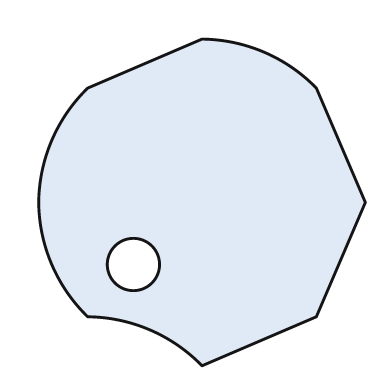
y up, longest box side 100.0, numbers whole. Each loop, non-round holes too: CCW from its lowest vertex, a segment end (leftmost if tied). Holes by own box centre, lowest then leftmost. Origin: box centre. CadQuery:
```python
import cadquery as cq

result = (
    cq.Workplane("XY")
    .moveTo(0.0, -50.0)
    .lineTo(35.0, -35.0)
    .lineTo(50.0, 0.0)
    .lineTo(35.0, 35.0)
    .threePointArc((19.0, 46.0), (0.0, 50.0))
    .lineTo(-35.0, 35.0)
    .threePointArc((-46.0, 19.0), (-50.0, 0.0))
    .threePointArc((-46.0, -19.0), (-35.0, -35.0))
    .threePointArc((-16.0, -39.0), (0.0, -50.0))
    .close()
    .moveTo(-21.0, -19.0)
    .circle(8.0)
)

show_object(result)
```